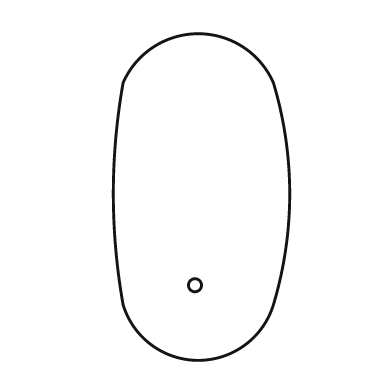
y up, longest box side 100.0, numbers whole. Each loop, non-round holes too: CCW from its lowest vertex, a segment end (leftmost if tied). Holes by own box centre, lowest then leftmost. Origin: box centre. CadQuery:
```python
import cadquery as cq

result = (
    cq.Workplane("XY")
    .moveTo(-24.0, -33.0)
    .threePointArc((-1.0, -50.0), (22.0, -33.0))
    .threePointArc((27.0, 1.0), (22.0, 35.0))
    .threePointArc((-1.0, 50.0), (-24.0, 35.0))
    .threePointArc((-27.0, 1.0), (-24.0, -33.0))
    .close()
    .moveTo(-2.0, -27.0)
    .circle(2.0)
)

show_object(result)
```